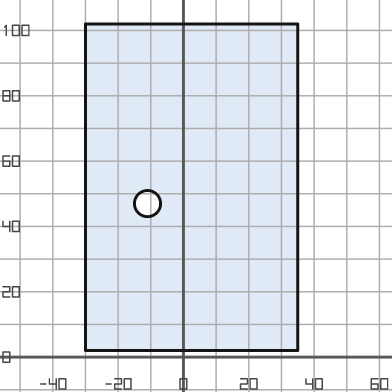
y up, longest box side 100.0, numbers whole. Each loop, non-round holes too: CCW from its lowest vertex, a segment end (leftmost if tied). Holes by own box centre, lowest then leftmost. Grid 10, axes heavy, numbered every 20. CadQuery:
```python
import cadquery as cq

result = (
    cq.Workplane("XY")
    .moveTo(-30.0, 2.0)
    .lineTo(35.0, 2.0)
    .lineTo(35.0, 102.0)
    .lineTo(-30.0, 102.0)
    .close()
    .moveTo(-11.0, 47.0)
    .circle(4.0)
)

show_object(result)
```